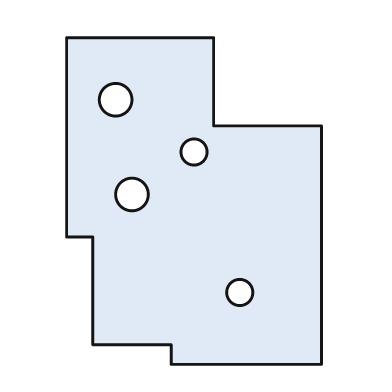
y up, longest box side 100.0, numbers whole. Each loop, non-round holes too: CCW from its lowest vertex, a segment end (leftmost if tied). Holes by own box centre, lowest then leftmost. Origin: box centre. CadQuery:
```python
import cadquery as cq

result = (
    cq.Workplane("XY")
    .moveTo(-7.0, -50.0)
    .lineTo(39.0, -50.0)
    .lineTo(39.0, 23.0)
    .lineTo(6.0, 23.0)
    .lineTo(6.0, 50.0)
    .lineTo(-39.0, 50.0)
    .lineTo(-39.0, -11.0)
    .lineTo(-31.0, -11.0)
    .lineTo(-31.0, -44.0)
    .lineTo(-7.0, -44.0)
    .close()
    .moveTo(14.0, -28.0)
    .circle(4.0)
    .moveTo(-19.0, 2.0)
    .circle(5.0)
    .moveTo(0.0, 15.0)
    .circle(4.0)
    .moveTo(-24.0, 31.0)
    .circle(5.0)
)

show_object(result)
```